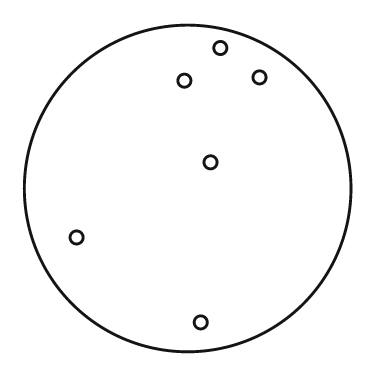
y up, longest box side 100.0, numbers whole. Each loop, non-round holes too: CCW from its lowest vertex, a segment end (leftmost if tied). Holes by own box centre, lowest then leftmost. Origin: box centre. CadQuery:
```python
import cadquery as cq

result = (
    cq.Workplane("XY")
    .moveTo(0.0, 0.0)
    .circle(50.0)
    .moveTo(4.0, -41.0)
    .circle(2.0)
    .moveTo(-34.0, -15.0)
    .circle(2.0)
    .moveTo(7.0, 8.0)
    .circle(2.0)
    .moveTo(-1.0, 33.0)
    .circle(2.0)
    .moveTo(22.0, 34.0)
    .circle(2.0)
    .moveTo(10.0, 43.0)
    .circle(2.0)
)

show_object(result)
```